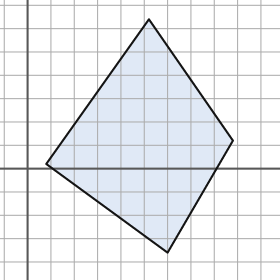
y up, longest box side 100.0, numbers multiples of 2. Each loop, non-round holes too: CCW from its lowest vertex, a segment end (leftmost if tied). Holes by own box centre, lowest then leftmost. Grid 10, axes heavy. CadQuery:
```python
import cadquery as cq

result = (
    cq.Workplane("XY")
    .moveTo(60.0, -36.0)
    .lineTo(88.0, 12.0)
    .lineTo(52.0, 64.0)
    .lineTo(8.0, 2.0)
    .close()
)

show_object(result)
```